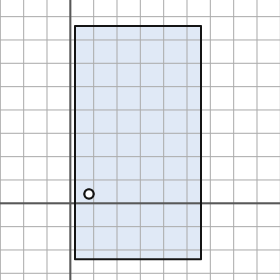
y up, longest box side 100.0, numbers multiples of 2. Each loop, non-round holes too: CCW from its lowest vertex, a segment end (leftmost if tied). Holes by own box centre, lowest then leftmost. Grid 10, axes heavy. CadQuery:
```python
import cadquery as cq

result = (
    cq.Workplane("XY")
    .moveTo(2.0, -24.0)
    .lineTo(56.0, -24.0)
    .lineTo(56.0, 76.0)
    .lineTo(2.0, 76.0)
    .close()
    .moveTo(8.0, 4.0)
    .circle(2.0)
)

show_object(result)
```